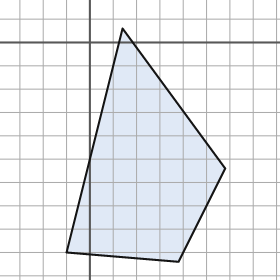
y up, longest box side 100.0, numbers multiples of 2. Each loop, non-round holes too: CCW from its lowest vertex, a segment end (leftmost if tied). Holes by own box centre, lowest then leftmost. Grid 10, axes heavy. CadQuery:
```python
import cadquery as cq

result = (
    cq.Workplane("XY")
    .moveTo(38.0, -94.0)
    .lineTo(58.0, -54.0)
    .lineTo(14.0, 6.0)
    .lineTo(-10.0, -90.0)
    .close()
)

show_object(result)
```